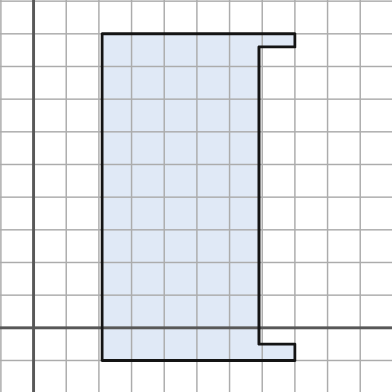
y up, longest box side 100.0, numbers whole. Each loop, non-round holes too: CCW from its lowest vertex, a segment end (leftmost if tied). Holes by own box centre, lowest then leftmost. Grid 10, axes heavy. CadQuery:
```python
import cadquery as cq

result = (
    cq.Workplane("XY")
    .moveTo(21.0, -10.0)
    .lineTo(80.0, -10.0)
    .lineTo(80.0, -5.0)
    .lineTo(69.0, -5.0)
    .lineTo(69.0, 86.0)
    .lineTo(80.0, 86.0)
    .lineTo(80.0, 90.0)
    .lineTo(21.0, 90.0)
    .close()
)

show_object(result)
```